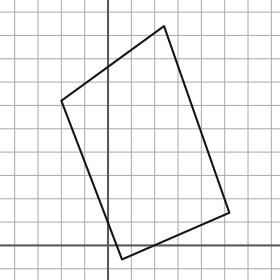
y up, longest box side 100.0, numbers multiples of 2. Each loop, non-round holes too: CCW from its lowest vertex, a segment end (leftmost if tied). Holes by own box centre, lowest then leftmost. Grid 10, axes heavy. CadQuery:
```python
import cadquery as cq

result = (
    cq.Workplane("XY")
    .moveTo(6.0, -6.0)
    .lineTo(52.0, 14.0)
    .lineTo(24.0, 94.0)
    .lineTo(-20.0, 62.0)
    .close()
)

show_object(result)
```